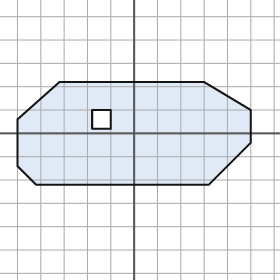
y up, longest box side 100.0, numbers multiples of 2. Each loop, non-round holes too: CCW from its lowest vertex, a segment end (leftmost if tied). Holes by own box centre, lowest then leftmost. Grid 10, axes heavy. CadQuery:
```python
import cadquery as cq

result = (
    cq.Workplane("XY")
    .moveTo(-42.0, -22.0)
    .lineTo(32.0, -22.0)
    .lineTo(50.0, -4.0)
    .lineTo(50.0, 10.0)
    .lineTo(30.0, 22.0)
    .lineTo(-32.0, 22.0)
    .lineTo(-50.0, 6.0)
    .lineTo(-50.0, -14.0)
    .close()
    .moveTo(-18.0, 2.0)
    .lineTo(-10.0, 2.0)
    .lineTo(-10.0, 10.0)
    .lineTo(-18.0, 10.0)
    .close()
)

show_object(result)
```